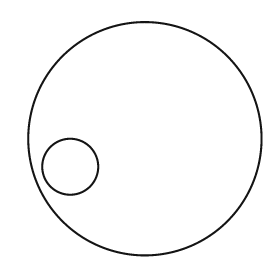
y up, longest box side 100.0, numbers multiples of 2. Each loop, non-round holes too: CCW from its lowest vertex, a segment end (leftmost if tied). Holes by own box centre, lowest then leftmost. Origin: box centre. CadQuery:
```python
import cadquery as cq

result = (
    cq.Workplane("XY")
    .moveTo(0.0, 0.0)
    .circle(50.0)
    .moveTo(-32.0, -12.0)
    .circle(12.0)
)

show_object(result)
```